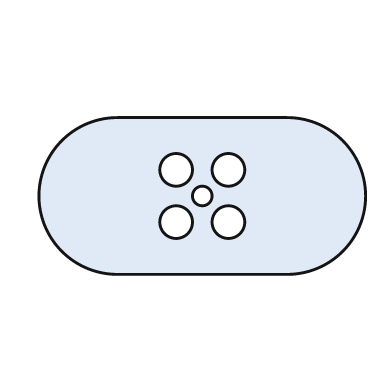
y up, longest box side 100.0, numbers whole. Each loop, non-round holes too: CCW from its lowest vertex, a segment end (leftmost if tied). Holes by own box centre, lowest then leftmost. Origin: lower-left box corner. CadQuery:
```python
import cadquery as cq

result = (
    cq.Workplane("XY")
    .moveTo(24.0, 0.0)
    .lineTo(76.0, 0.0)
    .threePointArc((100.0, 24.0), (76.0, 48.0))
    .lineTo(24.0, 48.0)
    .threePointArc((0.0, 24.0), (24.0, 0.0))
    .close()
    .moveTo(42.0, 16.0)
    .circle(5.0)
    .moveTo(58.0, 16.0)
    .circle(5.0)
    .moveTo(50.0, 24.0)
    .circle(3.0)
    .moveTo(42.0, 32.0)
    .circle(5.0)
    .moveTo(58.0, 32.0)
    .circle(5.0)
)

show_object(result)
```